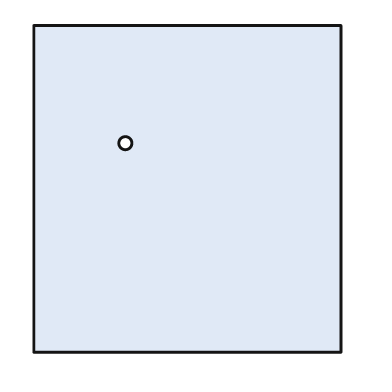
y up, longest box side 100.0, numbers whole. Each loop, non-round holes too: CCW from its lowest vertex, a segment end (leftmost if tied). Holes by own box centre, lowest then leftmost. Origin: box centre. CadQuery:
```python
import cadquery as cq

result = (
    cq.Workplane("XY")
    .moveTo(-47.0, -50.0)
    .lineTo(47.0, -50.0)
    .lineTo(47.0, 50.0)
    .lineTo(-47.0, 50.0)
    .close()
    .moveTo(-19.0, 14.0)
    .circle(2.0)
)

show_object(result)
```